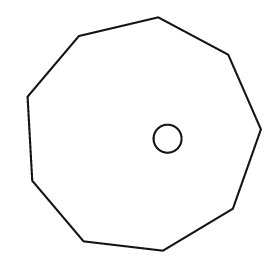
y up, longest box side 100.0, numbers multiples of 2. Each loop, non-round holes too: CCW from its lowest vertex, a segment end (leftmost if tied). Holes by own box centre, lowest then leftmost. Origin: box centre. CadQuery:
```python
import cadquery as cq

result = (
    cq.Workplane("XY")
    .moveTo(8.0, -50.0)
    .lineTo(38.0, -32.0)
    .lineTo(50.0, 2.0)
    .lineTo(36.0, 34.0)
    .lineTo(6.0, 50.0)
    .lineTo(-28.0, 42.0)
    .lineTo(-50.0, 16.0)
    .lineTo(-48.0, -20.0)
    .lineTo(-26.0, -46.0)
    .close()
    .moveTo(10.0, -2.0)
    .circle(6.0)
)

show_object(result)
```